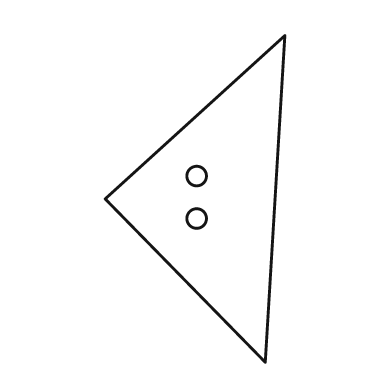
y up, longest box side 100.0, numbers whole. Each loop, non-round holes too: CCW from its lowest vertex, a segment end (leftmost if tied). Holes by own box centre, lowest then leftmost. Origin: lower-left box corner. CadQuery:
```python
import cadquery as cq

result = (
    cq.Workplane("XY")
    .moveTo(49.0, 0.0)
    .lineTo(55.0, 100.0)
    .lineTo(0.0, 50.0)
    .close()
    .moveTo(28.0, 44.0)
    .circle(3.0)
    .moveTo(28.0, 57.0)
    .circle(3.0)
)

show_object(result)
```